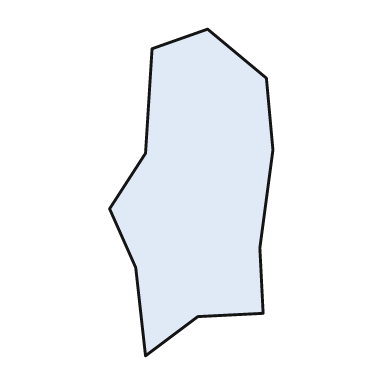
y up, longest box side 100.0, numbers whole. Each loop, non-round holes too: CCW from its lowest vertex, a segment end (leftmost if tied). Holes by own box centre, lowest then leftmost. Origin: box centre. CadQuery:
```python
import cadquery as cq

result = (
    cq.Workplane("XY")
    .moveTo(-14.0, -50.0)
    .lineTo(2.0, -38.0)
    .lineTo(22.0, -37.0)
    .lineTo(21.0, -17.0)
    .lineTo(25.0, 13.0)
    .lineTo(23.0, 35.0)
    .lineTo(5.0, 50.0)
    .lineTo(-12.0, 44.0)
    .lineTo(-14.0, 12.0)
    .lineTo(-25.0, -5.0)
    .lineTo(-17.0, -23.0)
    .close()
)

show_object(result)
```